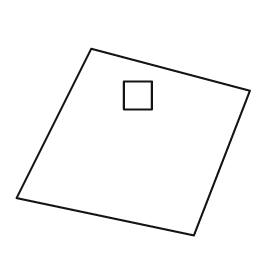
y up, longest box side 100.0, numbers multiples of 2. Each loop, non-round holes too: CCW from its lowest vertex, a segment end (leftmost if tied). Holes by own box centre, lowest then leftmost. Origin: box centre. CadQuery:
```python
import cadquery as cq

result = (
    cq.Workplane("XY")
    .moveTo(26.0, -40.0)
    .lineTo(50.0, 22.0)
    .lineTo(-18.0, 40.0)
    .lineTo(-50.0, -24.0)
    .close()
    .moveTo(-4.0, 14.0)
    .lineTo(8.0, 14.0)
    .lineTo(8.0, 26.0)
    .lineTo(-4.0, 26.0)
    .close()
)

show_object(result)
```